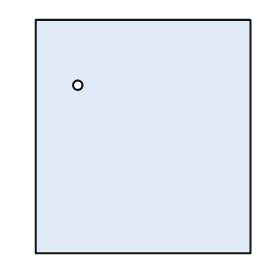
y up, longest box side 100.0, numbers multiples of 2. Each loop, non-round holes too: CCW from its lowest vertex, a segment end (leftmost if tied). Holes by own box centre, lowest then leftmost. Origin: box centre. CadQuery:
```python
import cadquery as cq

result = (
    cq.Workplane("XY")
    .moveTo(-46.0, -50.0)
    .lineTo(46.0, -50.0)
    .lineTo(46.0, 50.0)
    .lineTo(-46.0, 50.0)
    .close()
    .moveTo(-28.0, 22.0)
    .circle(2.0)
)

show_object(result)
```